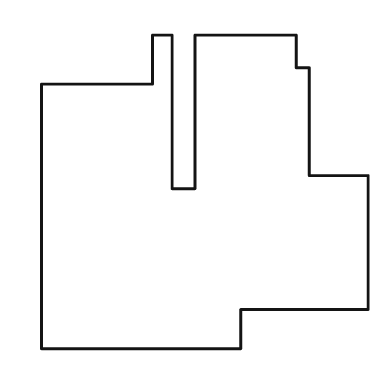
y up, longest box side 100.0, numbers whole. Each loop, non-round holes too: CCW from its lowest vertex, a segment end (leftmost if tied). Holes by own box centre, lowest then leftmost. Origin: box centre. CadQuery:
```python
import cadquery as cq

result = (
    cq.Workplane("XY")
    .moveTo(-50.0, -48.0)
    .lineTo(11.0, -48.0)
    .lineTo(11.0, -36.0)
    .lineTo(50.0, -36.0)
    .lineTo(50.0, 5.0)
    .lineTo(32.0, 5.0)
    .lineTo(32.0, 38.0)
    .lineTo(28.0, 38.0)
    .lineTo(28.0, 48.0)
    .lineTo(-3.0, 48.0)
    .lineTo(-3.0, 1.0)
    .lineTo(-10.0, 1.0)
    .lineTo(-10.0, 48.0)
    .lineTo(-16.0, 48.0)
    .lineTo(-16.0, 33.0)
    .lineTo(-50.0, 33.0)
    .close()
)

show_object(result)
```